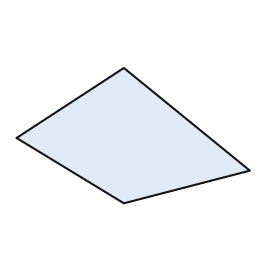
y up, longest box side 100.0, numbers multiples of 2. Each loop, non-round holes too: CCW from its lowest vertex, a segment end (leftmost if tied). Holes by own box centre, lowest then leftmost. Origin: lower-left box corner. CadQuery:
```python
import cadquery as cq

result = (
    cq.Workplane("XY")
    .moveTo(46.0, 0.0)
    .lineTo(100.0, 14.0)
    .lineTo(46.0, 58.0)
    .lineTo(0.0, 28.0)
    .close()
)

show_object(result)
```